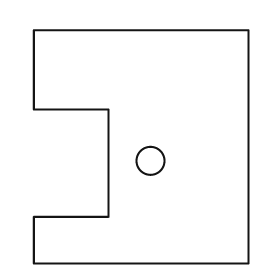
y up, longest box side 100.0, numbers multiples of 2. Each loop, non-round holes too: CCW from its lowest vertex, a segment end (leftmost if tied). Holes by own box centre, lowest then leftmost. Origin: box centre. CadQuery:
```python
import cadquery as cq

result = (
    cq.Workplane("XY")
    .moveTo(-46.0, -50.0)
    .lineTo(46.0, -50.0)
    .lineTo(46.0, 50.0)
    .lineTo(-46.0, 50.0)
    .lineTo(-46.0, 16.0)
    .lineTo(-14.0, 16.0)
    .lineTo(-14.0, -30.0)
    .lineTo(-46.0, -30.0)
    .close()
    .moveTo(4.0, -6.0)
    .circle(6.0)
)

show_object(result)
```